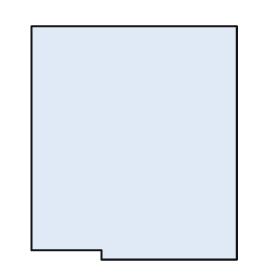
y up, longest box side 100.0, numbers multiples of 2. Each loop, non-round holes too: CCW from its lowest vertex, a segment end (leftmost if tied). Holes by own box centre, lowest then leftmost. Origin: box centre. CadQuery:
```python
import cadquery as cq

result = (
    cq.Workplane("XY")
    .moveTo(-14.0, -50.0)
    .lineTo(44.0, -50.0)
    .lineTo(44.0, 50.0)
    .lineTo(-44.0, 50.0)
    .lineTo(-44.0, -46.0)
    .lineTo(-14.0, -46.0)
    .close()
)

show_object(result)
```